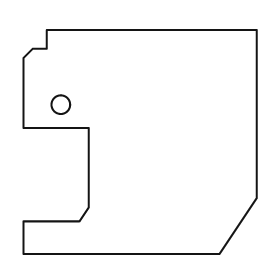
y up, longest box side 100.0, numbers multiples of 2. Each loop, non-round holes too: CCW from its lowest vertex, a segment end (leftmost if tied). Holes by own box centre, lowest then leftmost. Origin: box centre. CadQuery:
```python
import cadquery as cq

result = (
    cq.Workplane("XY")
    .moveTo(-50.0, -48.0)
    .lineTo(34.0, -48.0)
    .lineTo(50.0, -24.0)
    .lineTo(50.0, 48.0)
    .lineTo(-40.0, 48.0)
    .lineTo(-40.0, 40.0)
    .lineTo(-46.0, 40.0)
    .lineTo(-50.0, 36.0)
    .lineTo(-50.0, 6.0)
    .lineTo(-22.0, 6.0)
    .lineTo(-22.0, -28.0)
    .lineTo(-26.0, -34.0)
    .lineTo(-50.0, -34.0)
    .close()
    .moveTo(-34.0, 16.0)
    .circle(4.0)
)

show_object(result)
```